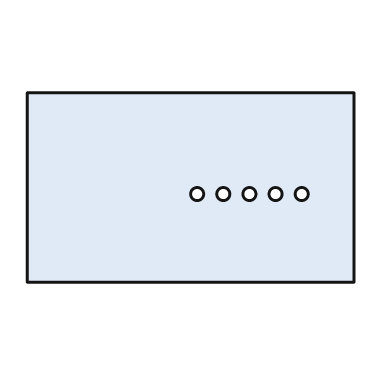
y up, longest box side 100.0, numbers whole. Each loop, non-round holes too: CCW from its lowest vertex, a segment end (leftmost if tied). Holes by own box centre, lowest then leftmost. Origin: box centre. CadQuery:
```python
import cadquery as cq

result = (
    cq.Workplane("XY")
    .moveTo(-50.0, -29.0)
    .lineTo(50.0, -29.0)
    .lineTo(50.0, 29.0)
    .lineTo(-50.0, 29.0)
    .close()
    .moveTo(2.0, -2.0)
    .circle(2.0)
    .moveTo(10.0, -2.0)
    .circle(2.0)
    .moveTo(18.0, -2.0)
    .circle(2.0)
    .moveTo(26.0, -2.0)
    .circle(2.0)
    .moveTo(34.0, -2.0)
    .circle(2.0)
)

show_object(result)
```